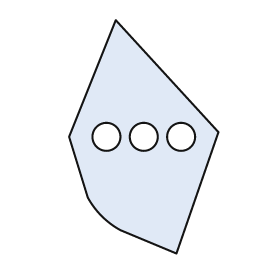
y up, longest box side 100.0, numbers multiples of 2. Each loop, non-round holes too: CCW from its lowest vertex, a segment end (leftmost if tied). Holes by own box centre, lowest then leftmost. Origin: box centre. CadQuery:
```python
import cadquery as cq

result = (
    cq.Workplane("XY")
    .moveTo(14.0, -50.0)
    .lineTo(32.0, 2.0)
    .lineTo(-12.0, 50.0)
    .lineTo(-32.0, 0.0)
    .lineTo(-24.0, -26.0)
    .threePointArc((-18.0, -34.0), (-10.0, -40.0))
    .close()
    .moveTo(-16.0, 0.0)
    .circle(6.0)
    .moveTo(0.0, 0.0)
    .circle(6.0)
    .moveTo(16.0, 0.0)
    .circle(6.0)
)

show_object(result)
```